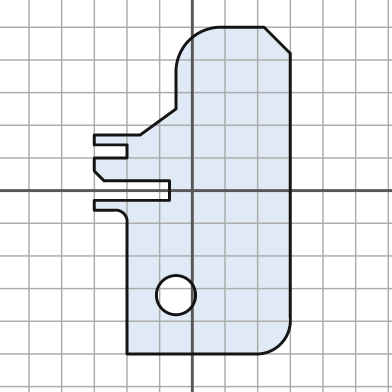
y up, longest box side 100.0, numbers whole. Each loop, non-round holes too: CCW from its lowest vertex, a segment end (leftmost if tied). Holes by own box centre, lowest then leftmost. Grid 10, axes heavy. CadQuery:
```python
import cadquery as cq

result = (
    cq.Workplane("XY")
    .moveTo(-20.0, -50.0)
    .lineTo(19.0, -50.0)
    .threePointArc((27.0, -47.0), (30.0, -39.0))
    .lineTo(30.0, 42.0)
    .lineTo(22.0, 50.0)
    .lineTo(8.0, 50.0)
    .threePointArc((-1.0, 46.0), (-5.0, 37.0))
    .lineTo(-5.0, 25.0)
    .lineTo(-16.0, 17.0)
    .lineTo(-30.0, 17.0)
    .lineTo(-30.0, 14.0)
    .lineTo(-20.0, 14.0)
    .lineTo(-20.0, 10.0)
    .lineTo(-30.0, 10.0)
    .lineTo(-30.0, 6.0)
    .lineTo(-27.0, 3.0)
    .lineTo(-7.0, 3.0)
    .lineTo(-7.0, -3.0)
    .lineTo(-30.0, -3.0)
    .lineTo(-30.0, -6.0)
    .lineTo(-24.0, -6.0)
    .threePointArc((-21.0, -7.0), (-20.0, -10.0))
    .close()
    .moveTo(-5.0, -32.0)
    .circle(6.0)
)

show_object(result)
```